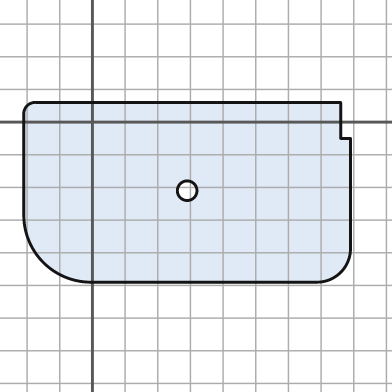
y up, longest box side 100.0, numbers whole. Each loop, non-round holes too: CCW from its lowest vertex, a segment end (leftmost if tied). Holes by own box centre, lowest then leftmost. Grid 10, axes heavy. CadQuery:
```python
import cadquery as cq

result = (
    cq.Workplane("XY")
    .moveTo(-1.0, -49.0)
    .lineTo(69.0, -49.0)
    .threePointArc((76.0, -46.0), (79.0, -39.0))
    .lineTo(79.0, -5.0)
    .lineTo(76.0, -5.0)
    .lineTo(76.0, 6.0)
    .lineTo(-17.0, 6.0)
    .threePointArc((-20.0, 5.0), (-21.0, 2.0))
    .lineTo(-21.0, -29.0)
    .threePointArc((-15.0, -43.0), (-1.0, -49.0))
    .close()
    .moveTo(29.0, -21.0)
    .circle(3.0)
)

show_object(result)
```